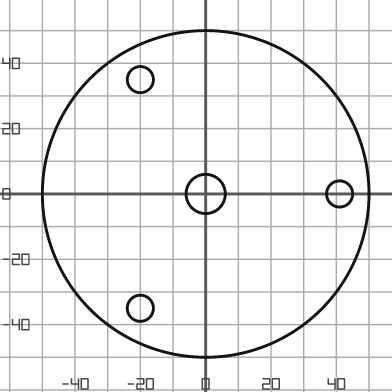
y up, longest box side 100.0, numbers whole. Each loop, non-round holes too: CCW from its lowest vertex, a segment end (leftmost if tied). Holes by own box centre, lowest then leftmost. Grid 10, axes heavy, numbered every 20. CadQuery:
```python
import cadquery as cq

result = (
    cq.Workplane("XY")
    .moveTo(0.0, 0.0)
    .circle(50.0)
    .moveTo(-20.0, -35.0)
    .circle(4.0)
    .moveTo(0.0, 0.0)
    .circle(6.0)
    .moveTo(41.0, 0.0)
    .circle(4.0)
    .moveTo(-20.0, 35.0)
    .circle(4.0)
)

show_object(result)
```